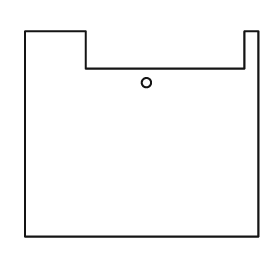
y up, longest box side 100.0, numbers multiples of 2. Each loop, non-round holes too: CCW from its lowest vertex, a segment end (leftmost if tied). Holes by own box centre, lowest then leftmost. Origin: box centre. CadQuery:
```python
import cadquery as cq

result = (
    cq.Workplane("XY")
    .moveTo(-50.0, -44.0)
    .lineTo(50.0, -44.0)
    .lineTo(50.0, 44.0)
    .lineTo(44.0, 44.0)
    .lineTo(44.0, 28.0)
    .lineTo(-24.0, 28.0)
    .lineTo(-24.0, 44.0)
    .lineTo(-50.0, 44.0)
    .close()
    .moveTo(2.0, 22.0)
    .circle(2.0)
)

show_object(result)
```